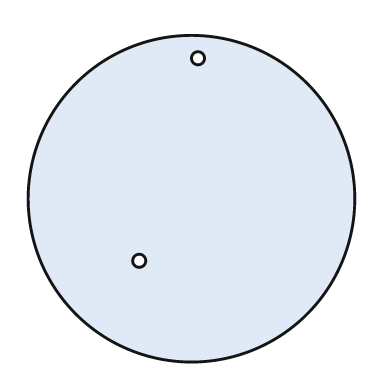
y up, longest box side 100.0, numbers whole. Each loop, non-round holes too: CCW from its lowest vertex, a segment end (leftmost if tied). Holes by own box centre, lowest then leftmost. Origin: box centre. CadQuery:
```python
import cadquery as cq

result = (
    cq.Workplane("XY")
    .moveTo(0.0, 0.0)
    .circle(50.0)
    .moveTo(-16.0, -19.0)
    .circle(2.0)
    .moveTo(2.0, 43.0)
    .circle(2.0)
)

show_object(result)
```